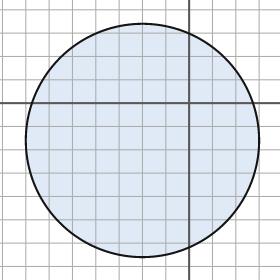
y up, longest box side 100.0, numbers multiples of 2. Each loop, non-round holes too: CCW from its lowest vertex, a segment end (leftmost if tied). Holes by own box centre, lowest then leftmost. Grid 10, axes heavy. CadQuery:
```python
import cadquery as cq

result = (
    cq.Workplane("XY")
    .moveTo(-20.0, -16.0)
    .circle(50.0)
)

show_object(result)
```